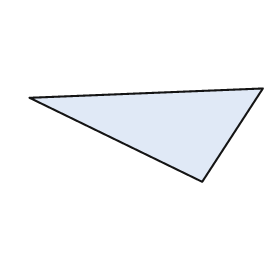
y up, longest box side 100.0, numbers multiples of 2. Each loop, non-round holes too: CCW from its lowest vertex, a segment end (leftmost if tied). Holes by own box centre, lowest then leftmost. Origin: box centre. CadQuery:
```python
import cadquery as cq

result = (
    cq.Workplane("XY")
    .moveTo(24.0, -20.0)
    .lineTo(50.0, 20.0)
    .lineTo(-50.0, 16.0)
    .close()
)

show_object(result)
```